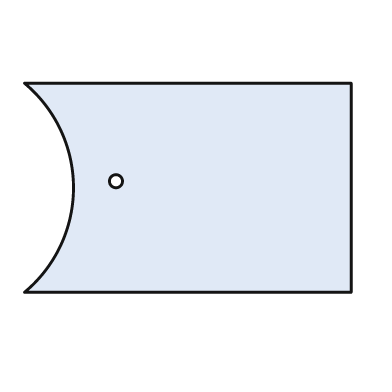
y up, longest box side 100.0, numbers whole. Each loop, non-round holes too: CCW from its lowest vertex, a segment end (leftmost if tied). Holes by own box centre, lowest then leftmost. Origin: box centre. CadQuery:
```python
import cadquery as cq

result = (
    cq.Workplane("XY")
    .moveTo(-50.0, -32.0)
    .lineTo(50.0, -32.0)
    .lineTo(50.0, 32.0)
    .lineTo(-50.0, 32.0)
    .threePointArc((-35.0, 0.0), (-50.0, -32.0))
    .close()
    .moveTo(-22.0, 2.0)
    .circle(2.0)
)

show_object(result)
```